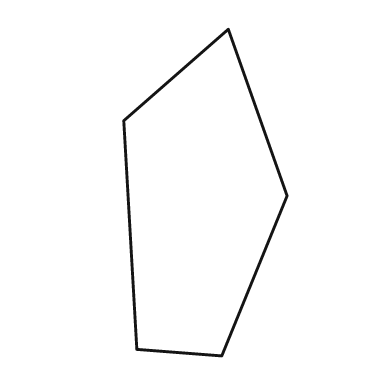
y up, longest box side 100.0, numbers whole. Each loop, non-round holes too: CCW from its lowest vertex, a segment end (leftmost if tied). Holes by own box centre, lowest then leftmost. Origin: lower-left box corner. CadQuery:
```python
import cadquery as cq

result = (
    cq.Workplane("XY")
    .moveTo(30.0, 0.0)
    .lineTo(50.0, 49.0)
    .lineTo(32.0, 100.0)
    .lineTo(0.0, 72.0)
    .lineTo(4.0, 2.0)
    .close()
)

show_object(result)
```